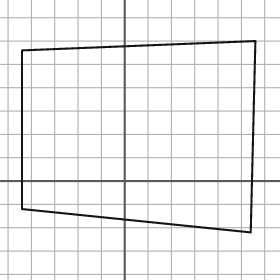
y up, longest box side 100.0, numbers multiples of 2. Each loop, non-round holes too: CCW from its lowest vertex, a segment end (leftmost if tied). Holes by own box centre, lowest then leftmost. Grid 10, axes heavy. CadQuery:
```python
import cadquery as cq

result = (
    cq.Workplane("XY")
    .moveTo(54.0, -22.0)
    .lineTo(56.0, 60.0)
    .lineTo(-44.0, 56.0)
    .lineTo(-44.0, -12.0)
    .close()
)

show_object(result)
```